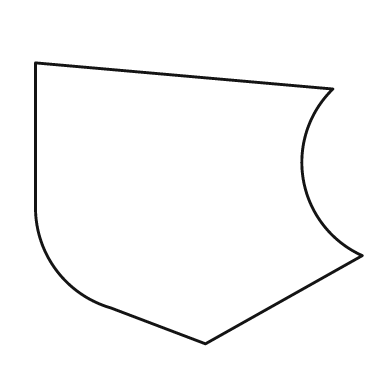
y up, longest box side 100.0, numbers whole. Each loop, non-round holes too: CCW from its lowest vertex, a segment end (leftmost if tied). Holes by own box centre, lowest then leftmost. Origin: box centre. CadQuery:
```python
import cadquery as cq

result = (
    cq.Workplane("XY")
    .moveTo(2.0, -43.0)
    .lineTo(50.0, -16.0)
    .threePointArc((32.0, 7.0), (41.0, 35.0))
    .lineTo(-50.0, 43.0)
    .lineTo(-50.0, 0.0)
    .threePointArc((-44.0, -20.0), (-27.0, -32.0))
    .close()
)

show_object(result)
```